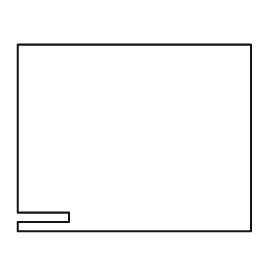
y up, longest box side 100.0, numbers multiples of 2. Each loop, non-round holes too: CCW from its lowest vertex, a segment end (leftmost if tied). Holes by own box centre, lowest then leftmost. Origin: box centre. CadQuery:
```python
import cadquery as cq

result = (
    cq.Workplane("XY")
    .moveTo(-50.0, -40.0)
    .lineTo(50.0, -40.0)
    .lineTo(50.0, 40.0)
    .lineTo(-50.0, 40.0)
    .lineTo(-50.0, -32.0)
    .lineTo(-28.0, -32.0)
    .lineTo(-28.0, -36.0)
    .lineTo(-50.0, -36.0)
    .close()
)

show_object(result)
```